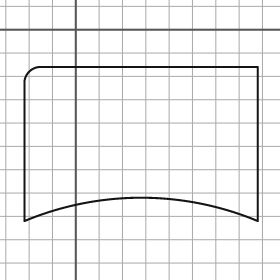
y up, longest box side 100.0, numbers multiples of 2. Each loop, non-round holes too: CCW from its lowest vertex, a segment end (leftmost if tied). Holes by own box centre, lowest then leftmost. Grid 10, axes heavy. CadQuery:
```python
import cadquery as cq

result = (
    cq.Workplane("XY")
    .moveTo(-22.0, -82.0)
    .threePointArc((28.0, -72.0), (78.0, -82.0))
    .lineTo(78.0, -16.0)
    .lineTo(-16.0, -16.0)
    .threePointArc((-20.0, -18.0), (-22.0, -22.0))
    .close()
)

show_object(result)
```